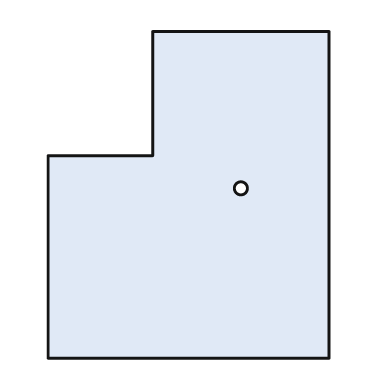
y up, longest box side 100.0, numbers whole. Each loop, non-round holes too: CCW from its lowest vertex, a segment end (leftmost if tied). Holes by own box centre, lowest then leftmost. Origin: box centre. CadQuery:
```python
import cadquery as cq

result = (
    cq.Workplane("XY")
    .moveTo(-43.0, -50.0)
    .lineTo(43.0, -50.0)
    .lineTo(43.0, 50.0)
    .lineTo(-11.0, 50.0)
    .lineTo(-11.0, 12.0)
    .lineTo(-43.0, 12.0)
    .close()
    .moveTo(16.0, 2.0)
    .circle(2.0)
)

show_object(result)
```